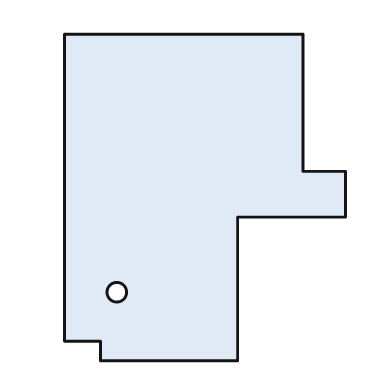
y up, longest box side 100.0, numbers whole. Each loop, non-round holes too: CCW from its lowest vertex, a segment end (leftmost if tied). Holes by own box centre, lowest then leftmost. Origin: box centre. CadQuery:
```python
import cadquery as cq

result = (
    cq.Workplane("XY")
    .moveTo(-32.0, -50.0)
    .lineTo(10.0, -50.0)
    .lineTo(10.0, -6.0)
    .lineTo(43.0, -6.0)
    .lineTo(43.0, 8.0)
    .lineTo(30.0, 8.0)
    .lineTo(30.0, 50.0)
    .lineTo(-43.0, 50.0)
    .lineTo(-43.0, -44.0)
    .lineTo(-32.0, -44.0)
    .close()
    .moveTo(-27.0, -29.0)
    .circle(3.0)
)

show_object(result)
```